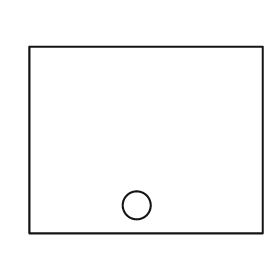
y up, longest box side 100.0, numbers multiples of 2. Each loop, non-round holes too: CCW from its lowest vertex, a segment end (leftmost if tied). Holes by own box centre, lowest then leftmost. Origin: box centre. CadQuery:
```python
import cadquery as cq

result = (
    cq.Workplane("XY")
    .moveTo(-50.0, -40.0)
    .lineTo(50.0, -40.0)
    .lineTo(50.0, 40.0)
    .lineTo(-50.0, 40.0)
    .close()
    .moveTo(-4.0, -28.0)
    .circle(6.0)
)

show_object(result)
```